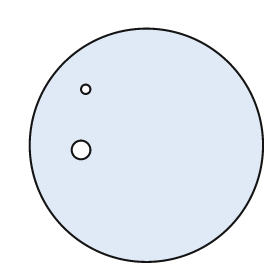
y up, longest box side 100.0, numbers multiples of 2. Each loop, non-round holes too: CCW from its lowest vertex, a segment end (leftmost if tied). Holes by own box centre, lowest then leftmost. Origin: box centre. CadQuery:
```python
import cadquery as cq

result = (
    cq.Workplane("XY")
    .moveTo(0.0, 0.0)
    .circle(50.0)
    .moveTo(-28.0, -2.0)
    .circle(4.0)
    .moveTo(-26.0, 24.0)
    .circle(2.0)
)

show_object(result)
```